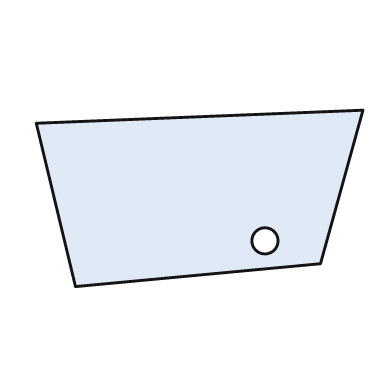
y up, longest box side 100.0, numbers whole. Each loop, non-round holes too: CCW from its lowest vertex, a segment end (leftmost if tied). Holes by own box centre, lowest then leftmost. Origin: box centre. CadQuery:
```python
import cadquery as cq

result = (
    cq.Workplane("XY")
    .moveTo(-38.0, -27.0)
    .lineTo(37.0, -20.0)
    .lineTo(50.0, 27.0)
    .lineTo(-50.0, 23.0)
    .close()
    .moveTo(20.0, -13.0)
    .circle(4.0)
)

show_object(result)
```